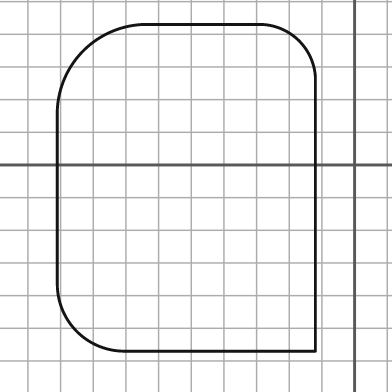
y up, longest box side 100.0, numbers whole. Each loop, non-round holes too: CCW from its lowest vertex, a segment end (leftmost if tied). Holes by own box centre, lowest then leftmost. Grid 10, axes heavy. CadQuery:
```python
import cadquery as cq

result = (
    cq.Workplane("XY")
    .moveTo(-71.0, -57.0)
    .lineTo(-12.0, -57.0)
    .lineTo(-12.0, 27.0)
    .threePointArc((-17.0, 38.0), (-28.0, 43.0))
    .lineTo(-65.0, 43.0)
    .threePointArc((-83.0, 35.0), (-91.0, 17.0))
    .lineTo(-91.0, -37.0)
    .threePointArc((-85.0, -51.0), (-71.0, -57.0))
    .close()
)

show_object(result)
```